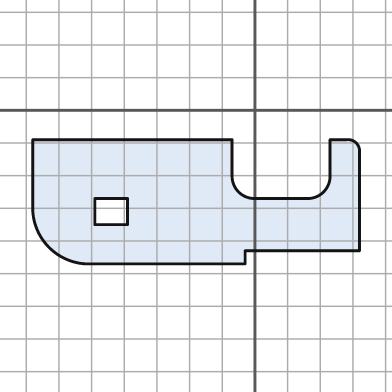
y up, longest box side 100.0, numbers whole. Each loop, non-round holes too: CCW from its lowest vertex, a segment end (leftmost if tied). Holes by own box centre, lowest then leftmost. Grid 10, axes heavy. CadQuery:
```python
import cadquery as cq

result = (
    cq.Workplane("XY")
    .moveTo(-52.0, -47.0)
    .lineTo(-3.0, -47.0)
    .lineTo(-3.0, -43.0)
    .lineTo(32.0, -43.0)
    .lineTo(32.0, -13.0)
    .threePointArc((31.0, -10.0), (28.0, -9.0))
    .lineTo(23.0, -9.0)
    .lineTo(23.0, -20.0)
    .threePointArc((21.0, -25.0), (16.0, -27.0))
    .lineTo(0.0, -27.0)
    .threePointArc((-5.0, -25.0), (-7.0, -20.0))
    .lineTo(-7.0, -9.0)
    .lineTo(-68.0, -9.0)
    .lineTo(-68.0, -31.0)
    .threePointArc((-63.0, -42.0), (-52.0, -47.0))
    .close()
    .moveTo(-49.0, -35.0)
    .lineTo(-39.0, -35.0)
    .lineTo(-39.0, -27.0)
    .lineTo(-49.0, -27.0)
    .close()
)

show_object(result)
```